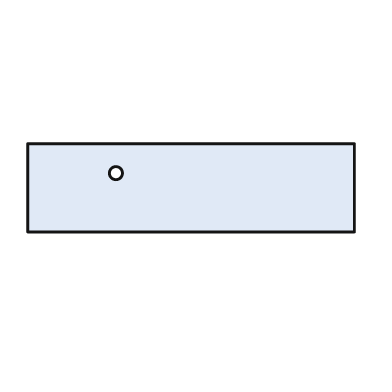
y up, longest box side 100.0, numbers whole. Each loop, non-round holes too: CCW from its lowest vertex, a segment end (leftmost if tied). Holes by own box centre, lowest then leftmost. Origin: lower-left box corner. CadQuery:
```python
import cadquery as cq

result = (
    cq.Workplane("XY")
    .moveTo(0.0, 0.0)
    .lineTo(100.0, 0.0)
    .lineTo(100.0, 27.0)
    .lineTo(0.0, 27.0)
    .close()
    .moveTo(27.0, 18.0)
    .circle(2.0)
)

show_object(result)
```